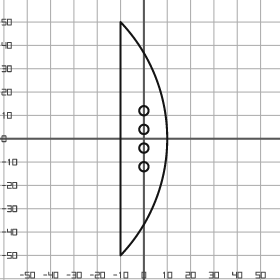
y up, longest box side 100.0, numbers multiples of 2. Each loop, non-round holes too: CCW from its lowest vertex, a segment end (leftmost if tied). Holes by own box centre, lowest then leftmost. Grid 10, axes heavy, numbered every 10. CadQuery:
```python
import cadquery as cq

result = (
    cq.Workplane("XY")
    .moveTo(-10.0, -50.0)
    .threePointArc((10.0, 0.0), (-10.0, 50.0))
    .close()
    .moveTo(0.0, -12.0)
    .circle(2.0)
    .moveTo(0.0, -4.0)
    .circle(2.0)
    .moveTo(0.0, 4.0)
    .circle(2.0)
    .moveTo(0.0, 12.0)
    .circle(2.0)
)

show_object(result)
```